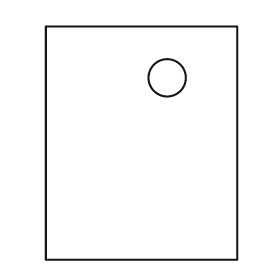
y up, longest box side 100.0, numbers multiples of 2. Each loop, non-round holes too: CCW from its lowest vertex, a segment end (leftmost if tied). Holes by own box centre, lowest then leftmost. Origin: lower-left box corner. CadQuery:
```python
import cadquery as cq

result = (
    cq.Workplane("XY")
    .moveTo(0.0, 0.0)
    .lineTo(82.0, 0.0)
    .lineTo(82.0, 100.0)
    .lineTo(0.0, 100.0)
    .close()
    .moveTo(52.0, 78.0)
    .circle(8.0)
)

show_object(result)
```